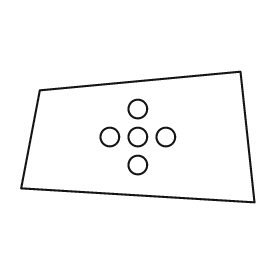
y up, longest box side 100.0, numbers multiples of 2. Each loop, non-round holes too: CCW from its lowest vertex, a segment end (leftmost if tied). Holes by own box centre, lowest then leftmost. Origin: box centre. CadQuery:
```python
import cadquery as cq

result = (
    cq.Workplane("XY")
    .moveTo(50.0, -28.0)
    .lineTo(44.0, 28.0)
    .lineTo(-42.0, 20.0)
    .lineTo(-50.0, -22.0)
    .close()
    .moveTo(0.0, -12.0)
    .circle(4.0)
    .moveTo(-12.0, 0.0)
    .circle(4.0)
    .moveTo(0.0, 0.0)
    .circle(4.0)
    .moveTo(12.0, 0.0)
    .circle(4.0)
    .moveTo(0.0, 12.0)
    .circle(4.0)
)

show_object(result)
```